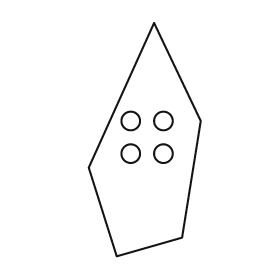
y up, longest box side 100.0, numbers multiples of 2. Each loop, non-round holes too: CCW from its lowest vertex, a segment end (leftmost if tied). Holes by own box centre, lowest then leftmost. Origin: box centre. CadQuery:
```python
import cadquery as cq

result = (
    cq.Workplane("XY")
    .moveTo(-12.0, -50.0)
    .lineTo(16.0, -42.0)
    .lineTo(24.0, 8.0)
    .lineTo(4.0, 50.0)
    .lineTo(-24.0, -12.0)
    .close()
    .moveTo(-6.0, -6.0)
    .circle(4.0)
    .moveTo(8.0, -6.0)
    .circle(4.0)
    .moveTo(-6.0, 8.0)
    .circle(4.0)
    .moveTo(8.0, 8.0)
    .circle(4.0)
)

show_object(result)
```